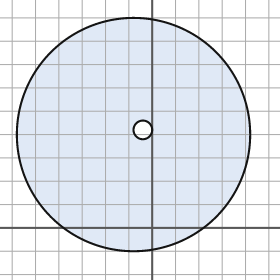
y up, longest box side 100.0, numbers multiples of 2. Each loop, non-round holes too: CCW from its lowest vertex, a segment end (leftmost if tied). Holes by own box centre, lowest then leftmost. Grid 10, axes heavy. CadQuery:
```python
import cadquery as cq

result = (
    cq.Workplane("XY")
    .moveTo(-8.0, 40.0)
    .circle(50.0)
    .moveTo(-4.0, 42.0)
    .circle(4.0)
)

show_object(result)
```